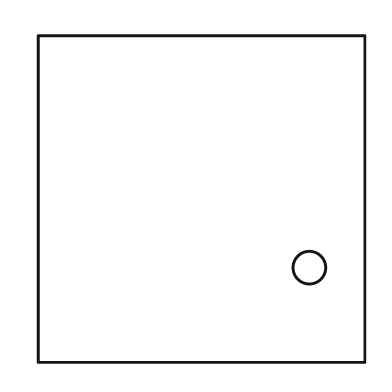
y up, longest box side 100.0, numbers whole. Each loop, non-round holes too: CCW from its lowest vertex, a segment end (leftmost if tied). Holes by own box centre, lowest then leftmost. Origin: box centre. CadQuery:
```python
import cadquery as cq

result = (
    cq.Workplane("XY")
    .moveTo(-50.0, -50.0)
    .lineTo(50.0, -50.0)
    .lineTo(50.0, 50.0)
    .lineTo(-50.0, 50.0)
    .close()
    .moveTo(33.0, -21.0)
    .circle(5.0)
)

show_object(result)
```